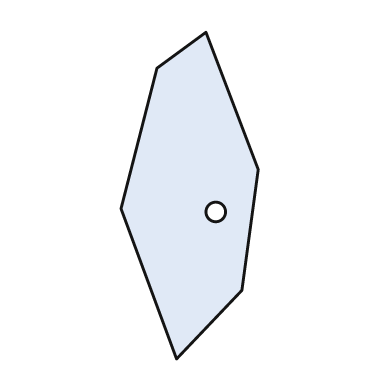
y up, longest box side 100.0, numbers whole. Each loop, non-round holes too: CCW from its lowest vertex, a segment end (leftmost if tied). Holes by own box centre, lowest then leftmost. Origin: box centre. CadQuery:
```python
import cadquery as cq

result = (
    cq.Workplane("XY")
    .moveTo(-4.0, -50.0)
    .lineTo(16.0, -29.0)
    .lineTo(21.0, 8.0)
    .lineTo(5.0, 50.0)
    .lineTo(-10.0, 39.0)
    .lineTo(-21.0, -4.0)
    .close()
    .moveTo(8.0, -5.0)
    .circle(3.0)
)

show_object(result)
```